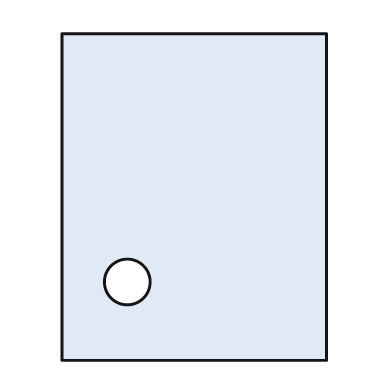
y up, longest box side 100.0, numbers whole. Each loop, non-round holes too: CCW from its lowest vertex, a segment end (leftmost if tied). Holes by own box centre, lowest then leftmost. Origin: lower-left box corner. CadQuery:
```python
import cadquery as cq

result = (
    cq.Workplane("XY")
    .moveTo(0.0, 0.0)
    .lineTo(81.0, 0.0)
    .lineTo(81.0, 100.0)
    .lineTo(0.0, 100.0)
    .close()
    .moveTo(20.0, 24.0)
    .circle(7.0)
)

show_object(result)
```